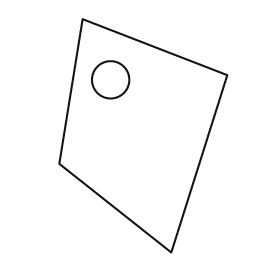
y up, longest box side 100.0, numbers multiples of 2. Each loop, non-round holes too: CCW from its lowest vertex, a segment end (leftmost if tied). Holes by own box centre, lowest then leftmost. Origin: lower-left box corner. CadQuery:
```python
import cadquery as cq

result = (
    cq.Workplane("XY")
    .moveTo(48.0, 0.0)
    .lineTo(72.0, 76.0)
    .lineTo(10.0, 100.0)
    .lineTo(0.0, 38.0)
    .close()
    .moveTo(22.0, 74.0)
    .circle(8.0)
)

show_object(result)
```